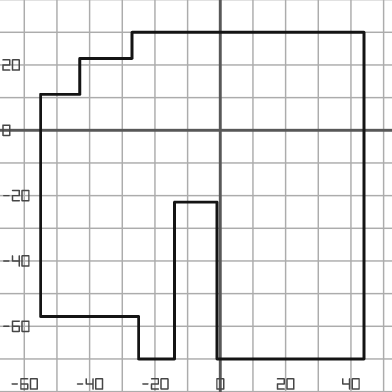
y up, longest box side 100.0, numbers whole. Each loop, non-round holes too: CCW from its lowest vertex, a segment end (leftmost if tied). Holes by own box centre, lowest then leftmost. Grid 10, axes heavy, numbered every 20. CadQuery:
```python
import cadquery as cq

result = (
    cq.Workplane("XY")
    .moveTo(-25.0, -70.0)
    .lineTo(-14.0, -70.0)
    .lineTo(-14.0, -22.0)
    .lineTo(-1.0, -22.0)
    .lineTo(-1.0, -70.0)
    .lineTo(44.0, -70.0)
    .lineTo(44.0, 30.0)
    .lineTo(-27.0, 30.0)
    .lineTo(-27.0, 22.0)
    .lineTo(-43.0, 22.0)
    .lineTo(-43.0, 11.0)
    .lineTo(-55.0, 11.0)
    .lineTo(-55.0, -57.0)
    .lineTo(-25.0, -57.0)
    .close()
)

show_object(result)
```